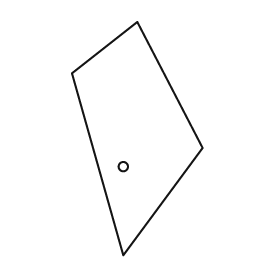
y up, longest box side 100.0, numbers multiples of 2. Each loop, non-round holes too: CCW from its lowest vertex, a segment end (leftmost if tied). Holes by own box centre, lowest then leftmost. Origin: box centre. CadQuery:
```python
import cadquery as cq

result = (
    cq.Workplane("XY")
    .moveTo(-6.0, -50.0)
    .lineTo(28.0, -4.0)
    .lineTo(0.0, 50.0)
    .lineTo(-28.0, 28.0)
    .close()
    .moveTo(-6.0, -12.0)
    .circle(2.0)
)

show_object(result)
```